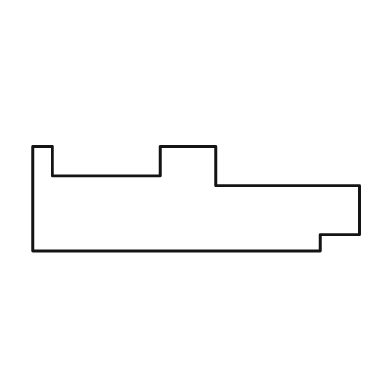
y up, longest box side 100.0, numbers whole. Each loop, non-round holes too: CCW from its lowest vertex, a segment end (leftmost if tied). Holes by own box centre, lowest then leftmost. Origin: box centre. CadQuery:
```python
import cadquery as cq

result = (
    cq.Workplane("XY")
    .moveTo(-50.0, -16.0)
    .lineTo(38.0, -16.0)
    .lineTo(38.0, -11.0)
    .lineTo(50.0, -11.0)
    .lineTo(50.0, 4.0)
    .lineTo(6.0, 4.0)
    .lineTo(6.0, 16.0)
    .lineTo(-11.0, 16.0)
    .lineTo(-11.0, 7.0)
    .lineTo(-44.0, 7.0)
    .lineTo(-44.0, 16.0)
    .lineTo(-50.0, 16.0)
    .close()
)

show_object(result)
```